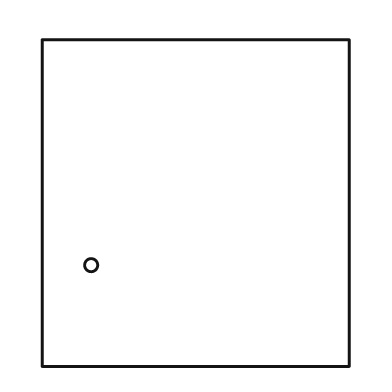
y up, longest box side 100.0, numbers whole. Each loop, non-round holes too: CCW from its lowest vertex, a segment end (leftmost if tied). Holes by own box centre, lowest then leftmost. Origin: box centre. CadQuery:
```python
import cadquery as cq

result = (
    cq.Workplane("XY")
    .moveTo(-47.0, -50.0)
    .lineTo(47.0, -50.0)
    .lineTo(47.0, 50.0)
    .lineTo(-47.0, 50.0)
    .close()
    .moveTo(-32.0, -19.0)
    .circle(2.0)
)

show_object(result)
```